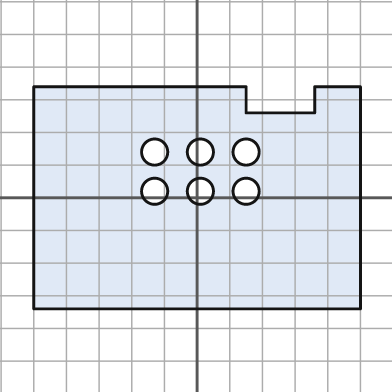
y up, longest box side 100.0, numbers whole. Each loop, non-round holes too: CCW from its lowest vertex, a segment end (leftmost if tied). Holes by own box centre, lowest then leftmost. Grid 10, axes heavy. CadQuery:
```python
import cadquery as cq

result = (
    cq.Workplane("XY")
    .moveTo(-50.0, -34.0)
    .lineTo(50.0, -34.0)
    .lineTo(50.0, 34.0)
    .lineTo(36.0, 34.0)
    .lineTo(36.0, 26.0)
    .lineTo(15.0, 26.0)
    .lineTo(15.0, 34.0)
    .lineTo(-50.0, 34.0)
    .close()
    .moveTo(-13.0, 2.0)
    .circle(4.0)
    .moveTo(1.0, 2.0)
    .circle(4.0)
    .moveTo(15.0, 2.0)
    .circle(4.0)
    .moveTo(-13.0, 14.0)
    .circle(4.0)
    .moveTo(1.0, 14.0)
    .circle(4.0)
    .moveTo(15.0, 14.0)
    .circle(4.0)
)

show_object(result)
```